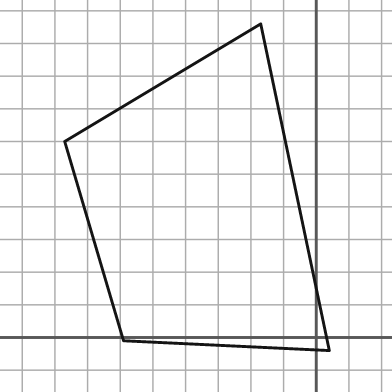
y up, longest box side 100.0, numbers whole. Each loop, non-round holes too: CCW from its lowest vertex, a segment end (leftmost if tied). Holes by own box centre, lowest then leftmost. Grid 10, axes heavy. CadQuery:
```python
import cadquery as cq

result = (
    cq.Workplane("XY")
    .moveTo(4.0, -4.0)
    .lineTo(-17.0, 96.0)
    .lineTo(-77.0, 60.0)
    .lineTo(-59.0, -1.0)
    .close()
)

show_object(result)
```